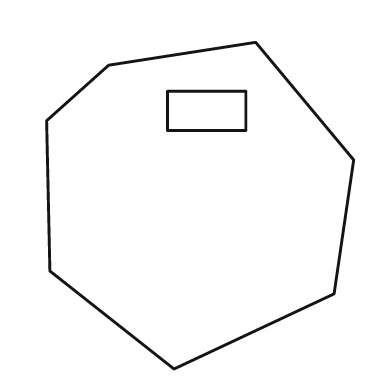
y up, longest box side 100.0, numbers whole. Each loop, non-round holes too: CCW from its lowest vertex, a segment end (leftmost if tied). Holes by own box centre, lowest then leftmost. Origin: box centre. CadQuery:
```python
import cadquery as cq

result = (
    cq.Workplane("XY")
    .moveTo(-8.0, -50.0)
    .lineTo(41.0, -27.0)
    .lineTo(47.0, 14.0)
    .lineTo(17.0, 50.0)
    .lineTo(-28.0, 43.0)
    .lineTo(-47.0, 26.0)
    .lineTo(-46.0, -20.0)
    .close()
    .moveTo(-10.0, 23.0)
    .lineTo(14.0, 23.0)
    .lineTo(14.0, 35.0)
    .lineTo(-10.0, 35.0)
    .close()
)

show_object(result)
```